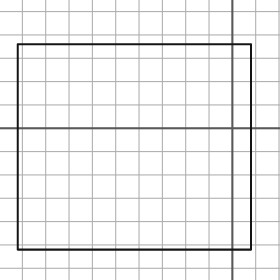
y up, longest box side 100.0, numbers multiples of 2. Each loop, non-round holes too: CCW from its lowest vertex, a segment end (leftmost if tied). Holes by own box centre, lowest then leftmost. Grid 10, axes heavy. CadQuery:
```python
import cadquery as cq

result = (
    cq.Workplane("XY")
    .moveTo(-92.0, -52.0)
    .lineTo(8.0, -52.0)
    .lineTo(8.0, 36.0)
    .lineTo(-92.0, 36.0)
    .close()
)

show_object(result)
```